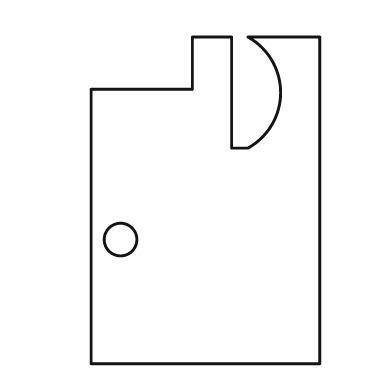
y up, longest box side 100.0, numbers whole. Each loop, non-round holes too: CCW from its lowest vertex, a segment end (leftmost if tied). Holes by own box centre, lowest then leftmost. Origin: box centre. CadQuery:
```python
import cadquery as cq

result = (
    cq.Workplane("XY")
    .moveTo(-35.0, -50.0)
    .lineTo(35.0, -50.0)
    .lineTo(35.0, 50.0)
    .lineTo(13.0, 50.0)
    .threePointArc((23.0, 33.0), (13.0, 16.0))
    .lineTo(8.0, 16.0)
    .lineTo(8.0, 50.0)
    .lineTo(-4.0, 50.0)
    .lineTo(-4.0, 34.0)
    .lineTo(-35.0, 34.0)
    .close()
    .moveTo(-26.0, -12.0)
    .circle(5.0)
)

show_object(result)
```